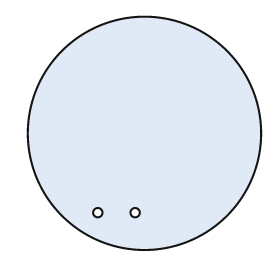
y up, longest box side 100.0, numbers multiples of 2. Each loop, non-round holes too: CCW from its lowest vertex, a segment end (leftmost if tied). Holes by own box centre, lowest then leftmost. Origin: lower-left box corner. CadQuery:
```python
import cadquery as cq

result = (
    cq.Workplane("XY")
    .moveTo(50.0, 50.0)
    .circle(50.0)
    .moveTo(30.0, 16.0)
    .circle(2.0)
    .moveTo(46.0, 16.0)
    .circle(2.0)
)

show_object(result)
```